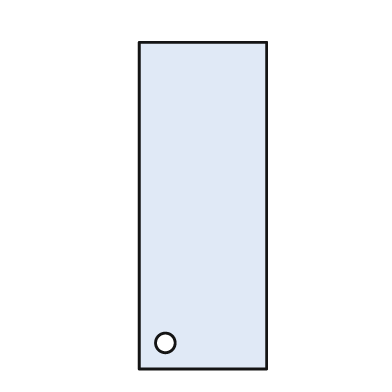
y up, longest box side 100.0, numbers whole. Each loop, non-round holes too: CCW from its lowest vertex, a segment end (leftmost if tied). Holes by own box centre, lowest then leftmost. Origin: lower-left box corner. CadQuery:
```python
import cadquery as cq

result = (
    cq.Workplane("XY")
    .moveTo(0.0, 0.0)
    .lineTo(39.0, 0.0)
    .lineTo(39.0, 100.0)
    .lineTo(0.0, 100.0)
    .close()
    .moveTo(8.0, 8.0)
    .circle(3.0)
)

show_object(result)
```